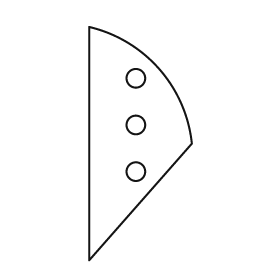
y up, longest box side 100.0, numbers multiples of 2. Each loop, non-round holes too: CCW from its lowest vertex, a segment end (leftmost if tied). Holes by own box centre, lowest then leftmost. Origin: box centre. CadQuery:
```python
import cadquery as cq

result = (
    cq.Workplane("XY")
    .moveTo(-22.0, -50.0)
    .lineTo(22.0, 0.0)
    .threePointArc((8.0, 32.0), (-22.0, 50.0))
    .close()
    .moveTo(-2.0, -12.0)
    .circle(4.0)
    .moveTo(-2.0, 8.0)
    .circle(4.0)
    .moveTo(-2.0, 28.0)
    .circle(4.0)
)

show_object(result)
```